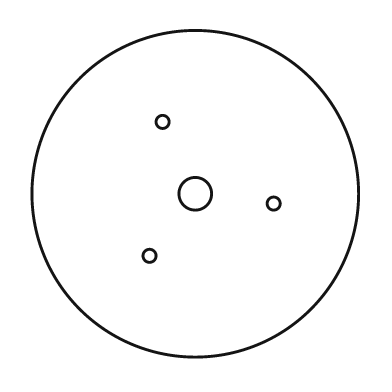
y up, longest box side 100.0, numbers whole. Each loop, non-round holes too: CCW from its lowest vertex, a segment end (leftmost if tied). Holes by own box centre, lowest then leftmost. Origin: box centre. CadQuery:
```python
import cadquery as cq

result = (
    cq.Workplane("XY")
    .moveTo(0.0, 0.0)
    .circle(50.0)
    .moveTo(-14.0, -19.0)
    .circle(2.0)
    .moveTo(24.0, -3.0)
    .circle(2.0)
    .moveTo(0.0, 0.0)
    .circle(5.0)
    .moveTo(-10.0, 22.0)
    .circle(2.0)
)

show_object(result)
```